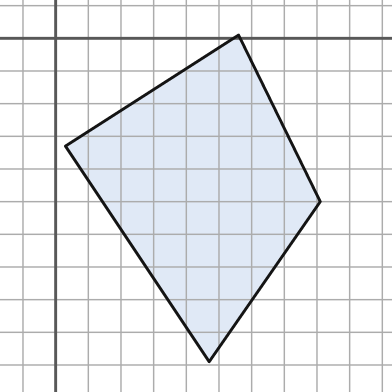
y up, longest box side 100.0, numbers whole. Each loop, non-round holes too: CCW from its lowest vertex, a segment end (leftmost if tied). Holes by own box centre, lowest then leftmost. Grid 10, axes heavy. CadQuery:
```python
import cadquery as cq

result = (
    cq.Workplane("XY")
    .moveTo(47.0, -99.0)
    .lineTo(81.0, -50.0)
    .lineTo(56.0, 1.0)
    .lineTo(3.0, -33.0)
    .close()
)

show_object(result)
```